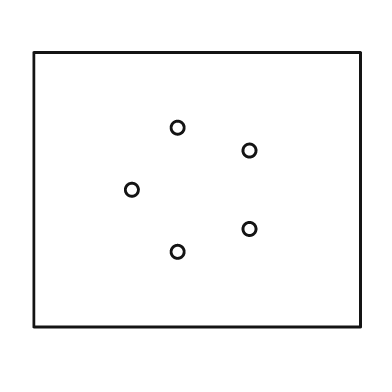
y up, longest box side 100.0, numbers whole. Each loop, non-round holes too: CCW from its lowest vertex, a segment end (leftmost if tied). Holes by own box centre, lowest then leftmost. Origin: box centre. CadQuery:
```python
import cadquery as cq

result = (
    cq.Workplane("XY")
    .moveTo(-50.0, -42.0)
    .lineTo(50.0, -42.0)
    .lineTo(50.0, 42.0)
    .lineTo(-50.0, 42.0)
    .close()
    .moveTo(-6.0, -19.0)
    .circle(2.0)
    .moveTo(16.0, -12.0)
    .circle(2.0)
    .moveTo(-20.0, 0.0)
    .circle(2.0)
    .moveTo(16.0, 12.0)
    .circle(2.0)
    .moveTo(-6.0, 19.0)
    .circle(2.0)
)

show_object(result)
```